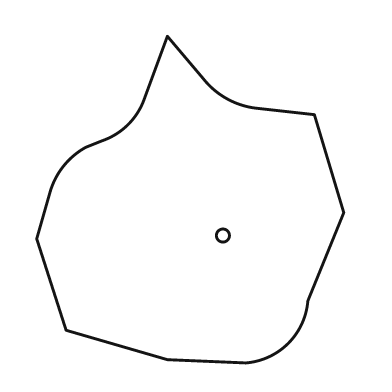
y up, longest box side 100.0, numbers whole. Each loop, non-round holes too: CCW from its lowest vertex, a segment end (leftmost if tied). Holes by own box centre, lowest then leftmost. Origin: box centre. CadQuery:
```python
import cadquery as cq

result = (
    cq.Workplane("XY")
    .moveTo(17.0, -50.0)
    .threePointArc((30.0, -44.0), (36.0, -31.0))
    .lineTo(47.0, -4.0)
    .lineTo(38.0, 26.0)
    .lineTo(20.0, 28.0)
    .threePointArc((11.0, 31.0), (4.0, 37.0))
    .lineTo(-7.0, 50.0)
    .lineTo(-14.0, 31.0)
    .threePointArc((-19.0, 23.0), (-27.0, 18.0))
    .lineTo(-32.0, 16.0)
    .threePointArc((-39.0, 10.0), (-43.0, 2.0))
    .lineTo(-47.0, -12.0)
    .lineTo(-38.0, -40.0)
    .lineTo(-7.0, -49.0)
    .close()
    .moveTo(10.0, -11.0)
    .circle(2.0)
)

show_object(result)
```